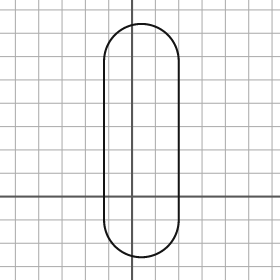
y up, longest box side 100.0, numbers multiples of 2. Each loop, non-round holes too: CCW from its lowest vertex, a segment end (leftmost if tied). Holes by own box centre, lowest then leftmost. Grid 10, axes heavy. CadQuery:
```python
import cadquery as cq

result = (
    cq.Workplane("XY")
    .moveTo(-12.0, -10.0)
    .threePointArc((4.0, -26.0), (20.0, -10.0))
    .lineTo(20.0, 58.0)
    .threePointArc((4.0, 74.0), (-12.0, 58.0))
    .close()
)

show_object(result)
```